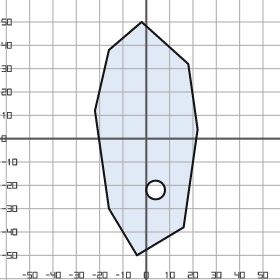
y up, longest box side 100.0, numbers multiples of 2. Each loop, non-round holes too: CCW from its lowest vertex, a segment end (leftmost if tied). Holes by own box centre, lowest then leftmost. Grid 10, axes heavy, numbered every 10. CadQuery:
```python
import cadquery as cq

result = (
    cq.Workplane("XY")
    .moveTo(-4.0, -50.0)
    .lineTo(16.0, -38.0)
    .lineTo(22.0, 4.0)
    .lineTo(18.0, 32.0)
    .lineTo(-2.0, 50.0)
    .lineTo(-16.0, 38.0)
    .lineTo(-22.0, 12.0)
    .lineTo(-16.0, -30.0)
    .close()
    .moveTo(4.0, -22.0)
    .circle(4.0)
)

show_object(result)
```